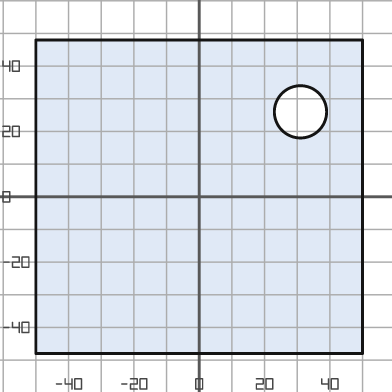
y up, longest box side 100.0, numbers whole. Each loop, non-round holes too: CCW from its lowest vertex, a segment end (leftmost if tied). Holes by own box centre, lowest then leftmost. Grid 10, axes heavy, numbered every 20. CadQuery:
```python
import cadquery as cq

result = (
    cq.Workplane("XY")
    .moveTo(-50.0, -48.0)
    .lineTo(50.0, -48.0)
    .lineTo(50.0, 48.0)
    .lineTo(-50.0, 48.0)
    .close()
    .moveTo(31.0, 26.0)
    .circle(8.0)
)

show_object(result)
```